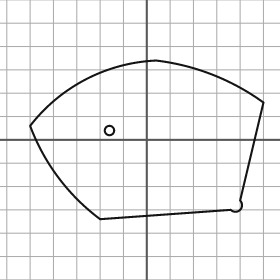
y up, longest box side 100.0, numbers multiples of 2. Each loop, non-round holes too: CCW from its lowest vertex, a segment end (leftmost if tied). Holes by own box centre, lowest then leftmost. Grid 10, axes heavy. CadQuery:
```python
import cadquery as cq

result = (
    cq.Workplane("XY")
    .moveTo(-20.0, -34.0)
    .lineTo(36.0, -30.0)
    .threePointArc((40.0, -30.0), (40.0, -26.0))
    .lineTo(50.0, 16.0)
    .threePointArc((28.0, 28.0), (4.0, 34.0))
    .threePointArc((-26.0, 26.0), (-50.0, 6.0))
    .threePointArc((-38.0, -16.0), (-20.0, -34.0))
    .close()
    .moveTo(-16.0, 4.0)
    .circle(2.0)
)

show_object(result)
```